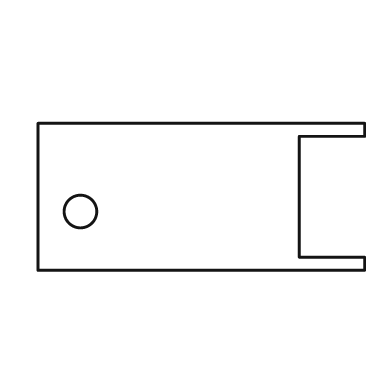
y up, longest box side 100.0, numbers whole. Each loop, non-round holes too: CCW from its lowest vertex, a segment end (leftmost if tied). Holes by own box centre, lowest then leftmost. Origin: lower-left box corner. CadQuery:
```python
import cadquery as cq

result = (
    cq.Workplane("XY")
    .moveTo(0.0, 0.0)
    .lineTo(100.0, 0.0)
    .lineTo(100.0, 4.0)
    .lineTo(80.0, 4.0)
    .lineTo(80.0, 41.0)
    .lineTo(100.0, 41.0)
    .lineTo(100.0, 45.0)
    .lineTo(0.0, 45.0)
    .close()
    .moveTo(13.0, 18.0)
    .circle(5.0)
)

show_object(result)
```